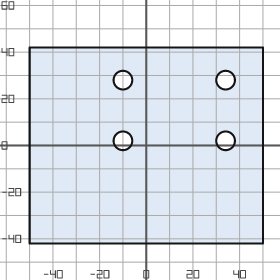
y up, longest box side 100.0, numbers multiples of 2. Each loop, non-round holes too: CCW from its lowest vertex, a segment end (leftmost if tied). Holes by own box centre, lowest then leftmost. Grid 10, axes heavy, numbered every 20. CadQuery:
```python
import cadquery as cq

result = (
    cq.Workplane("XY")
    .moveTo(-50.0, -42.0)
    .lineTo(50.0, -42.0)
    .lineTo(50.0, 42.0)
    .lineTo(-50.0, 42.0)
    .close()
    .moveTo(-10.0, 2.0)
    .circle(4.0)
    .moveTo(34.0, 2.0)
    .circle(4.0)
    .moveTo(-10.0, 28.0)
    .circle(4.0)
    .moveTo(34.0, 28.0)
    .circle(4.0)
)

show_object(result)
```